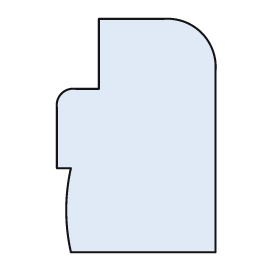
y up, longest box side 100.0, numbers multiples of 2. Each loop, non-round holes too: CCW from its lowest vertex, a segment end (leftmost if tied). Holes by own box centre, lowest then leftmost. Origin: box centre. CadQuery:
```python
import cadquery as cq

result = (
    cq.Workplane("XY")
    .moveTo(-28.0, -50.0)
    .lineTo(34.0, -50.0)
    .lineTo(34.0, 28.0)
    .threePointArc((28.0, 44.0), (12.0, 50.0))
    .lineTo(-16.0, 50.0)
    .lineTo(-16.0, 20.0)
    .lineTo(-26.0, 20.0)
    .threePointArc((-32.0, 18.0), (-34.0, 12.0))
    .lineTo(-34.0, -14.0)
    .lineTo(-28.0, -14.0)
    .threePointArc((-30.0, -32.0), (-28.0, -50.0))
    .close()
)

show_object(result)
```